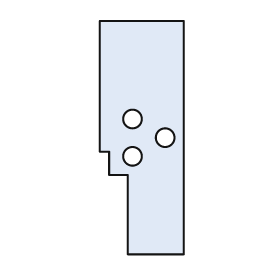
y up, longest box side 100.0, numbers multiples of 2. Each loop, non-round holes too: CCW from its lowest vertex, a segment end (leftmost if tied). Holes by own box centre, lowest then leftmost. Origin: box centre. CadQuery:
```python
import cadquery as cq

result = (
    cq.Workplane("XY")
    .moveTo(-6.0, -50.0)
    .lineTo(18.0, -50.0)
    .lineTo(18.0, 50.0)
    .lineTo(-18.0, 50.0)
    .lineTo(-18.0, -6.0)
    .lineTo(-14.0, -6.0)
    .lineTo(-14.0, -16.0)
    .lineTo(-6.0, -16.0)
    .close()
    .moveTo(-4.0, -8.0)
    .circle(4.0)
    .moveTo(10.0, 0.0)
    .circle(4.0)
    .moveTo(-4.0, 8.0)
    .circle(4.0)
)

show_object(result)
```